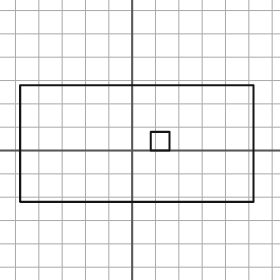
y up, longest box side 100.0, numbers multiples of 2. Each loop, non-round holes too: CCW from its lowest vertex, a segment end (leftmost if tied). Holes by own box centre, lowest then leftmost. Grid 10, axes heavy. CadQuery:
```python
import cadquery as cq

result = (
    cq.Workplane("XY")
    .moveTo(-48.0, -22.0)
    .lineTo(52.0, -22.0)
    .lineTo(52.0, 28.0)
    .lineTo(-48.0, 28.0)
    .close()
    .moveTo(8.0, 0.0)
    .lineTo(16.0, 0.0)
    .lineTo(16.0, 8.0)
    .lineTo(8.0, 8.0)
    .close()
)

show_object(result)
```